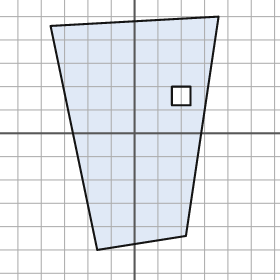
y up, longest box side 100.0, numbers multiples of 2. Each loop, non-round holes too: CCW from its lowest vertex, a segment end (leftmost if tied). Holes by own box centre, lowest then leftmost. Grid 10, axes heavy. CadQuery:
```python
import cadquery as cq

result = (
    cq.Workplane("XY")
    .moveTo(-16.0, -50.0)
    .lineTo(22.0, -44.0)
    .lineTo(36.0, 50.0)
    .lineTo(-36.0, 46.0)
    .close()
    .moveTo(16.0, 12.0)
    .lineTo(24.0, 12.0)
    .lineTo(24.0, 20.0)
    .lineTo(16.0, 20.0)
    .close()
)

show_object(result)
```